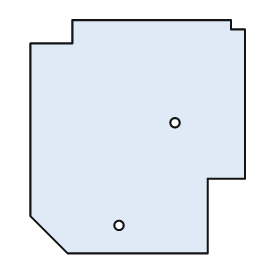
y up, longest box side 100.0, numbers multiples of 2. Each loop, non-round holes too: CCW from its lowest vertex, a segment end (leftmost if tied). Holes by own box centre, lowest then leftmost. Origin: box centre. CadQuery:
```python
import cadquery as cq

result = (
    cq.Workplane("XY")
    .moveTo(-30.0, -50.0)
    .lineTo(30.0, -50.0)
    .lineTo(30.0, -18.0)
    .lineTo(46.0, -18.0)
    .lineTo(46.0, 46.0)
    .lineTo(40.0, 46.0)
    .lineTo(40.0, 50.0)
    .lineTo(-28.0, 50.0)
    .lineTo(-28.0, 40.0)
    .lineTo(-46.0, 40.0)
    .lineTo(-46.0, -34.0)
    .close()
    .moveTo(-8.0, -38.0)
    .circle(2.0)
    .moveTo(16.0, 6.0)
    .circle(2.0)
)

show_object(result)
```